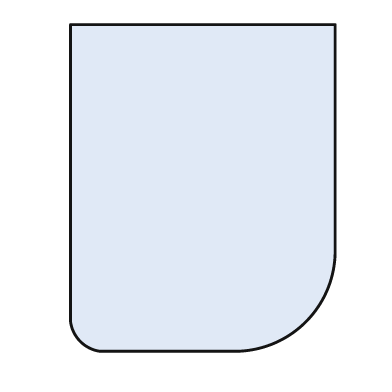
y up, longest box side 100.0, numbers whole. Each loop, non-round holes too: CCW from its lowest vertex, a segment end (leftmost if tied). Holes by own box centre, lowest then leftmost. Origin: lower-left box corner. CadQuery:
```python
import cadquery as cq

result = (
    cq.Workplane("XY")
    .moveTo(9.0, 0.0)
    .lineTo(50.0, 0.0)
    .threePointArc((72.0, 9.0), (81.0, 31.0))
    .lineTo(81.0, 100.0)
    .lineTo(0.0, 100.0)
    .lineTo(0.0, 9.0)
    .threePointArc((3.0, 3.0), (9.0, 0.0))
    .close()
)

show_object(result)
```